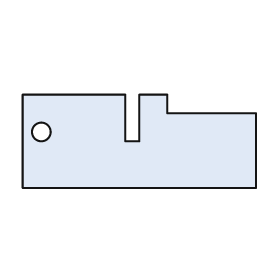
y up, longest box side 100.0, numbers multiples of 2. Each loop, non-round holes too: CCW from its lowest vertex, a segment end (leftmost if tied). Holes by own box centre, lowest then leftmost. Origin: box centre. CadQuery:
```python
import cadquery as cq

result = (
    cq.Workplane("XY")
    .moveTo(-50.0, -20.0)
    .lineTo(50.0, -20.0)
    .lineTo(50.0, 12.0)
    .lineTo(12.0, 12.0)
    .lineTo(12.0, 20.0)
    .lineTo(0.0, 20.0)
    .lineTo(0.0, 0.0)
    .lineTo(-6.0, 0.0)
    .lineTo(-6.0, 20.0)
    .lineTo(-50.0, 20.0)
    .close()
    .moveTo(-42.0, 4.0)
    .circle(4.0)
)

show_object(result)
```